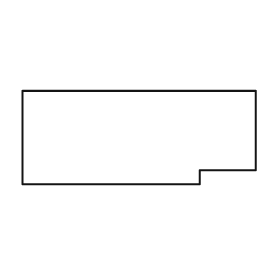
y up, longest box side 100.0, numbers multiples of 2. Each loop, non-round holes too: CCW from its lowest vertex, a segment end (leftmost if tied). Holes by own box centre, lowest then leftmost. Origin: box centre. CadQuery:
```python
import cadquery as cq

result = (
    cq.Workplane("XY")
    .moveTo(-50.0, -20.0)
    .lineTo(26.0, -20.0)
    .lineTo(26.0, -14.0)
    .lineTo(50.0, -14.0)
    .lineTo(50.0, 20.0)
    .lineTo(-50.0, 20.0)
    .close()
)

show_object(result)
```